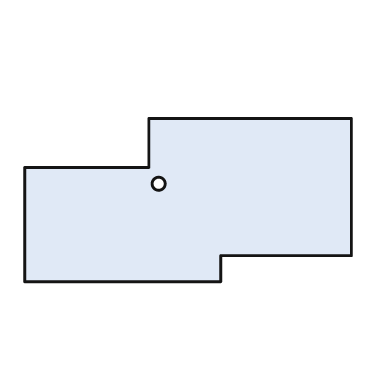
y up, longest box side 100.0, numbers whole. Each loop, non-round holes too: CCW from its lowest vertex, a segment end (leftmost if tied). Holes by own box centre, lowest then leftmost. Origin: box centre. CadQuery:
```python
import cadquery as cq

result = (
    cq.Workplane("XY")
    .moveTo(-50.0, -25.0)
    .lineTo(10.0, -25.0)
    .lineTo(10.0, -17.0)
    .lineTo(50.0, -17.0)
    .lineTo(50.0, 25.0)
    .lineTo(-12.0, 25.0)
    .lineTo(-12.0, 10.0)
    .lineTo(-50.0, 10.0)
    .close()
    .moveTo(-9.0, 5.0)
    .circle(2.0)
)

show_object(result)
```